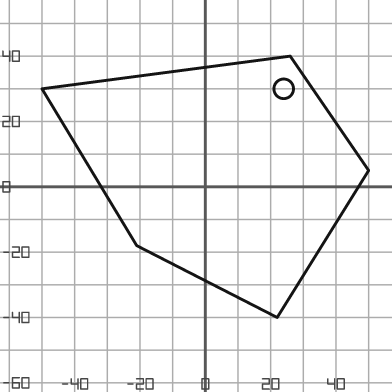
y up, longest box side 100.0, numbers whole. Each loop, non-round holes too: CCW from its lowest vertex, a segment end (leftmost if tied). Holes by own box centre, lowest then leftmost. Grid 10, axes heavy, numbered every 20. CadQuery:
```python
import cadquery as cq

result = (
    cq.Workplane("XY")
    .moveTo(22.0, -40.0)
    .lineTo(50.0, 5.0)
    .lineTo(26.0, 40.0)
    .lineTo(-50.0, 30.0)
    .lineTo(-21.0, -18.0)
    .close()
    .moveTo(24.0, 30.0)
    .circle(3.0)
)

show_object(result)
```